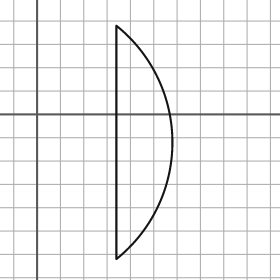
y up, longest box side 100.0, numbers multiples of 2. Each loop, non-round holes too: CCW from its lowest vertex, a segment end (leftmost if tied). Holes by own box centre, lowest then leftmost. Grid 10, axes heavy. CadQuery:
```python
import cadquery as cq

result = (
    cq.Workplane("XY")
    .moveTo(34.0, -62.0)
    .threePointArc((58.0, -12.0), (34.0, 38.0))
    .close()
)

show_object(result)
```